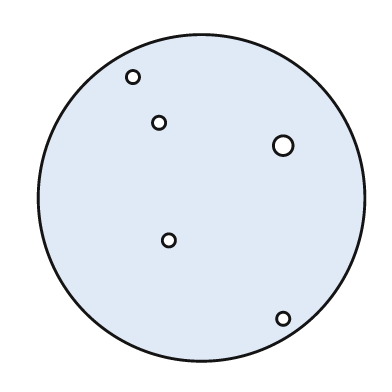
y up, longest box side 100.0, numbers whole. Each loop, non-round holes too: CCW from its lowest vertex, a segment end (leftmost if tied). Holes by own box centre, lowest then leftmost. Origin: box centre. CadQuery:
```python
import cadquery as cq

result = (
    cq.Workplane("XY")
    .moveTo(0.0, 0.0)
    .circle(50.0)
    .moveTo(25.0, -37.0)
    .circle(2.0)
    .moveTo(-10.0, -13.0)
    .circle(2.0)
    .moveTo(25.0, 16.0)
    .circle(3.0)
    .moveTo(-13.0, 23.0)
    .circle(2.0)
    .moveTo(-21.0, 37.0)
    .circle(2.0)
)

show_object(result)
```